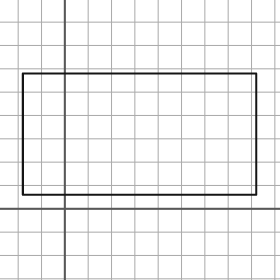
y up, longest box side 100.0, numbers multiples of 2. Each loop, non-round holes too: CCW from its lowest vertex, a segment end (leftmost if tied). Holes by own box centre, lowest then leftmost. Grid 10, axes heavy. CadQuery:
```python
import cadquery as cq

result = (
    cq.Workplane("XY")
    .moveTo(-18.0, 6.0)
    .lineTo(82.0, 6.0)
    .lineTo(82.0, 58.0)
    .lineTo(-18.0, 58.0)
    .close()
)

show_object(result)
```